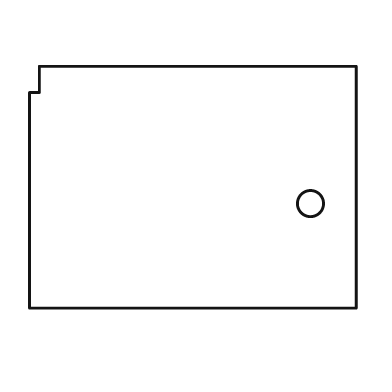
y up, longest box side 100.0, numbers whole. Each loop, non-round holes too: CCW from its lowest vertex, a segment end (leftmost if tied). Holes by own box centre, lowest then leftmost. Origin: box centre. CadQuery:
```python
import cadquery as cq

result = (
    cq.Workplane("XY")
    .moveTo(-50.0, -37.0)
    .lineTo(50.0, -37.0)
    .lineTo(50.0, 37.0)
    .lineTo(-47.0, 37.0)
    .lineTo(-47.0, 29.0)
    .lineTo(-50.0, 29.0)
    .close()
    .moveTo(36.0, -5.0)
    .circle(4.0)
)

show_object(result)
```